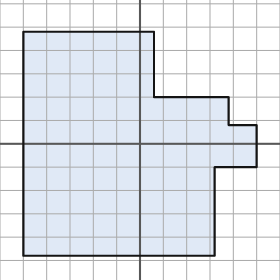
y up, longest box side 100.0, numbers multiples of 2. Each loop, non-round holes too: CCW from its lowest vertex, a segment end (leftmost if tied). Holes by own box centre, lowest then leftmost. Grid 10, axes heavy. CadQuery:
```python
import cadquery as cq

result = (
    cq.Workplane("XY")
    .moveTo(-50.0, -48.0)
    .lineTo(32.0, -48.0)
    .lineTo(32.0, -10.0)
    .lineTo(50.0, -10.0)
    .lineTo(50.0, 8.0)
    .lineTo(38.0, 8.0)
    .lineTo(38.0, 20.0)
    .lineTo(6.0, 20.0)
    .lineTo(6.0, 48.0)
    .lineTo(-50.0, 48.0)
    .close()
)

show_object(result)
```